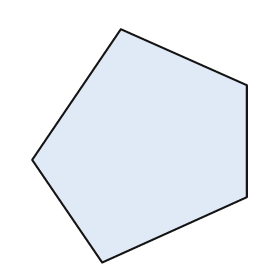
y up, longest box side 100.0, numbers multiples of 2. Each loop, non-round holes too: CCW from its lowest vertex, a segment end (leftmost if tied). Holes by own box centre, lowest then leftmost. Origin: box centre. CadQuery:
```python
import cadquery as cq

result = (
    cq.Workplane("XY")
    .moveTo(-16.0, -50.0)
    .lineTo(46.0, -22.0)
    .lineTo(46.0, 26.0)
    .lineTo(-8.0, 50.0)
    .lineTo(-46.0, -6.0)
    .close()
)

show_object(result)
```